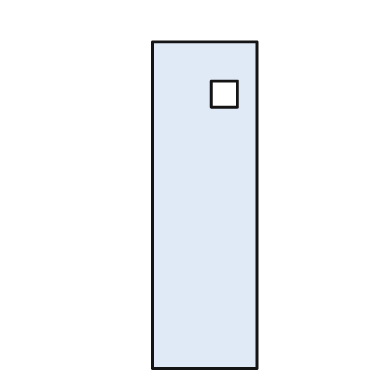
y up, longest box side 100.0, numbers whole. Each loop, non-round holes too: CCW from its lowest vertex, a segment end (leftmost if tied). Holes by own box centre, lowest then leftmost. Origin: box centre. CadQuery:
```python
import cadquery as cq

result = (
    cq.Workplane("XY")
    .moveTo(-16.0, -50.0)
    .lineTo(16.0, -50.0)
    .lineTo(16.0, 50.0)
    .lineTo(-16.0, 50.0)
    .close()
    .moveTo(2.0, 30.0)
    .lineTo(10.0, 30.0)
    .lineTo(10.0, 38.0)
    .lineTo(2.0, 38.0)
    .close()
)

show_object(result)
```